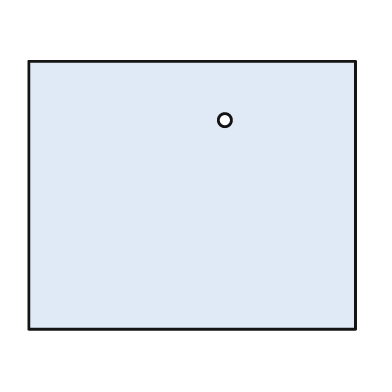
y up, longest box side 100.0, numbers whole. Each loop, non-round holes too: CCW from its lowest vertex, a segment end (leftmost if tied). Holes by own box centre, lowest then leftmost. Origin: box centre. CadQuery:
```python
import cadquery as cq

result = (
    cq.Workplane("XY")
    .moveTo(-50.0, -41.0)
    .lineTo(50.0, -41.0)
    .lineTo(50.0, 41.0)
    .lineTo(-50.0, 41.0)
    .close()
    .moveTo(10.0, 23.0)
    .circle(2.0)
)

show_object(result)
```